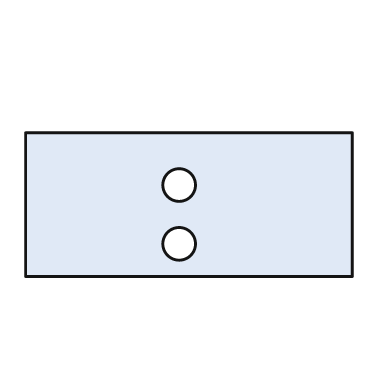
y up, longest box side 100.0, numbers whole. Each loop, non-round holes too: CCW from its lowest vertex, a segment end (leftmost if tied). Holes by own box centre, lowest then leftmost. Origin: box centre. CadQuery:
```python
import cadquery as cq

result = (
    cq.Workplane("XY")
    .moveTo(-50.0, -22.0)
    .lineTo(50.0, -22.0)
    .lineTo(50.0, 22.0)
    .lineTo(-50.0, 22.0)
    .close()
    .moveTo(-3.0, -12.0)
    .circle(5.0)
    .moveTo(-3.0, 6.0)
    .circle(5.0)
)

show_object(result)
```